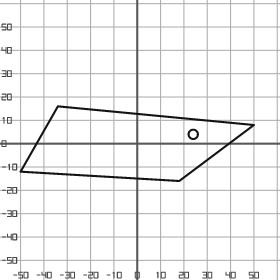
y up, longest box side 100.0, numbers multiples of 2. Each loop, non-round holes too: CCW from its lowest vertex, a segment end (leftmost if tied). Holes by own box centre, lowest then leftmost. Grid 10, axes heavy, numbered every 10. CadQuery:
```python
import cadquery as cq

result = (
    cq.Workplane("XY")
    .moveTo(18.0, -16.0)
    .lineTo(50.0, 8.0)
    .lineTo(-34.0, 16.0)
    .lineTo(-50.0, -12.0)
    .close()
    .moveTo(24.0, 4.0)
    .circle(2.0)
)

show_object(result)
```